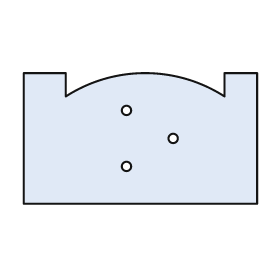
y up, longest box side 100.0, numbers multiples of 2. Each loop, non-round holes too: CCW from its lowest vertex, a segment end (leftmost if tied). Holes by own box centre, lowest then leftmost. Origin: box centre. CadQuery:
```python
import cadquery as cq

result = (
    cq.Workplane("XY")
    .moveTo(-50.0, -28.0)
    .lineTo(50.0, -28.0)
    .lineTo(50.0, 28.0)
    .lineTo(36.0, 28.0)
    .lineTo(36.0, 18.0)
    .threePointArc((2.0, 28.0), (-32.0, 18.0))
    .lineTo(-32.0, 28.0)
    .lineTo(-50.0, 28.0)
    .close()
    .moveTo(-6.0, -12.0)
    .circle(2.0)
    .moveTo(14.0, 0.0)
    .circle(2.0)
    .moveTo(-6.0, 12.0)
    .circle(2.0)
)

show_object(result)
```